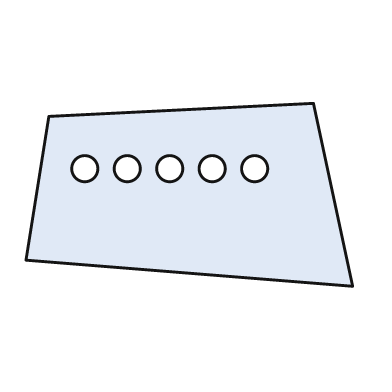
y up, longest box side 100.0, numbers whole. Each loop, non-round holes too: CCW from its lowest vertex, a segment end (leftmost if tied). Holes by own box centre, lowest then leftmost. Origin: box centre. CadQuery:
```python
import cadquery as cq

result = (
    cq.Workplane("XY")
    .moveTo(50.0, -28.0)
    .lineTo(38.0, 28.0)
    .lineTo(-43.0, 24.0)
    .lineTo(-50.0, -20.0)
    .close()
    .moveTo(-32.0, 8.0)
    .circle(4.0)
    .moveTo(-19.0, 8.0)
    .circle(4.0)
    .moveTo(-6.0, 8.0)
    .circle(4.0)
    .moveTo(7.0, 8.0)
    .circle(4.0)
    .moveTo(20.0, 8.0)
    .circle(4.0)
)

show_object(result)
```